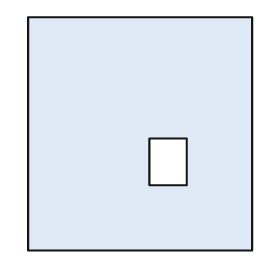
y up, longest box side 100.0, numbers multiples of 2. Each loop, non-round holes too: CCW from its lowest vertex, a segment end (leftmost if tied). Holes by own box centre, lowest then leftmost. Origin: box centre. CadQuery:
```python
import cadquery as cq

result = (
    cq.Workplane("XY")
    .moveTo(-48.0, -50.0)
    .lineTo(48.0, -50.0)
    .lineTo(48.0, 50.0)
    .lineTo(-48.0, 50.0)
    .close()
    .moveTo(4.0, -22.0)
    .lineTo(20.0, -22.0)
    .lineTo(20.0, -2.0)
    .lineTo(4.0, -2.0)
    .close()
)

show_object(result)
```